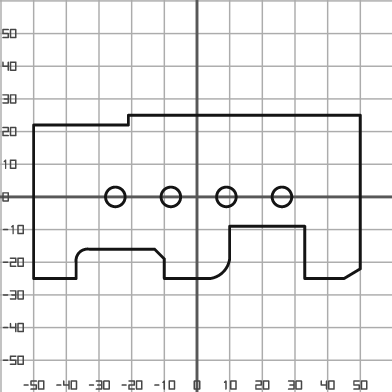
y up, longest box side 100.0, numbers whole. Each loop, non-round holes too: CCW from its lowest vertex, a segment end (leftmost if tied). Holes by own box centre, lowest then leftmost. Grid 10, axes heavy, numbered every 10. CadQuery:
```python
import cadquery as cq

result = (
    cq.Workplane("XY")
    .moveTo(-50.0, -25.0)
    .lineTo(-37.0, -25.0)
    .lineTo(-37.0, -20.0)
    .threePointArc((-36.0, -17.0), (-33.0, -16.0))
    .lineTo(-13.0, -16.0)
    .lineTo(-10.0, -19.0)
    .lineTo(-10.0, -25.0)
    .lineTo(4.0, -25.0)
    .threePointArc((8.0, -23.0), (10.0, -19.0))
    .lineTo(10.0, -9.0)
    .lineTo(33.0, -9.0)
    .lineTo(33.0, -25.0)
    .lineTo(45.0, -25.0)
    .lineTo(50.0, -22.0)
    .lineTo(50.0, 25.0)
    .lineTo(-21.0, 25.0)
    .lineTo(-21.0, 22.0)
    .lineTo(-50.0, 22.0)
    .close()
    .moveTo(-25.0, 0.0)
    .circle(3.0)
    .moveTo(-8.0, 0.0)
    .circle(3.0)
    .moveTo(9.0, 0.0)
    .circle(3.0)
    .moveTo(26.0, 0.0)
    .circle(3.0)
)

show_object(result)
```